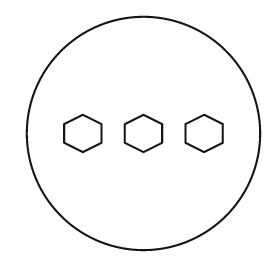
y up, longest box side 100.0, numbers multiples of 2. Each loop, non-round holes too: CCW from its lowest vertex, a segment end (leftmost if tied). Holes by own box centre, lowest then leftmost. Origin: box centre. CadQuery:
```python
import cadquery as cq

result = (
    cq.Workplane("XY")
    .moveTo(0.0, 0.0)
    .circle(50.0)
    .moveTo(-26.0, -8.0)
    .lineTo(-18.0, -4.0)
    .lineTo(-18.0, 4.0)
    .lineTo(-26.0, 8.0)
    .lineTo(-34.0, 4.0)
    .lineTo(-34.0, -4.0)
    .close()
    .moveTo(0.0, -8.0)
    .lineTo(8.0, -4.0)
    .lineTo(8.0, 4.0)
    .lineTo(0.0, 8.0)
    .lineTo(-8.0, 4.0)
    .lineTo(-8.0, -4.0)
    .close()
    .moveTo(26.0, -8.0)
    .lineTo(34.0, -4.0)
    .lineTo(34.0, 4.0)
    .lineTo(26.0, 8.0)
    .lineTo(18.0, 4.0)
    .lineTo(18.0, -4.0)
    .close()
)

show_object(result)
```